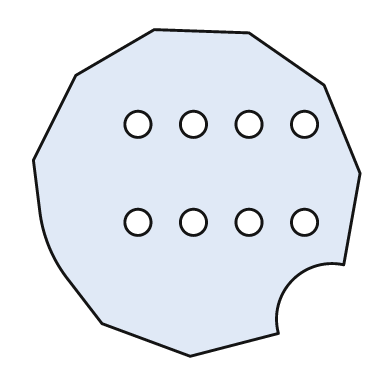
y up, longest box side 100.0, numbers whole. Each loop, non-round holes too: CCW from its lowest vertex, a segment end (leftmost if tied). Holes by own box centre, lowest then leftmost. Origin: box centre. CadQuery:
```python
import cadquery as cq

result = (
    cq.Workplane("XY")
    .moveTo(-2.0, -50.0)
    .lineTo(25.0, -43.0)
    .threePointArc((29.0, -27.0), (45.0, -22.0))
    .lineTo(50.0, 6.0)
    .lineTo(39.0, 33.0)
    .lineTo(16.0, 49.0)
    .lineTo(-13.0, 50.0)
    .lineTo(-37.0, 36.0)
    .lineTo(-50.0, 10.0)
    .lineTo(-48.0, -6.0)
    .threePointArc((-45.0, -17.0), (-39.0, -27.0))
    .lineTo(-29.0, -40.0)
    .close()
    .moveTo(-18.0, -9.0)
    .circle(4.0)
    .moveTo(-1.0, -9.0)
    .circle(4.0)
    .moveTo(16.0, -9.0)
    .circle(4.0)
    .moveTo(33.0, -9.0)
    .circle(4.0)
    .moveTo(-18.0, 21.0)
    .circle(4.0)
    .moveTo(-1.0, 21.0)
    .circle(4.0)
    .moveTo(16.0, 21.0)
    .circle(4.0)
    .moveTo(33.0, 21.0)
    .circle(4.0)
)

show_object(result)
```